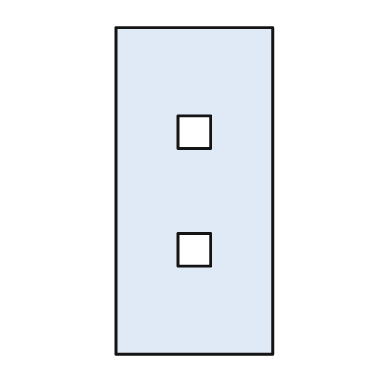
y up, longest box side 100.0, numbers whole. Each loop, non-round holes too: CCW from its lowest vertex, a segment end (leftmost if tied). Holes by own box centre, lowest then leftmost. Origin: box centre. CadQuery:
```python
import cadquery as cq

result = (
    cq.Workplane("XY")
    .moveTo(-24.0, -50.0)
    .lineTo(24.0, -50.0)
    .lineTo(24.0, 50.0)
    .lineTo(-24.0, 50.0)
    .close()
    .moveTo(-5.0, -23.0)
    .lineTo(5.0, -23.0)
    .lineTo(5.0, -13.0)
    .lineTo(-5.0, -13.0)
    .close()
    .moveTo(-5.0, 13.0)
    .lineTo(5.0, 13.0)
    .lineTo(5.0, 23.0)
    .lineTo(-5.0, 23.0)
    .close()
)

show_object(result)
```